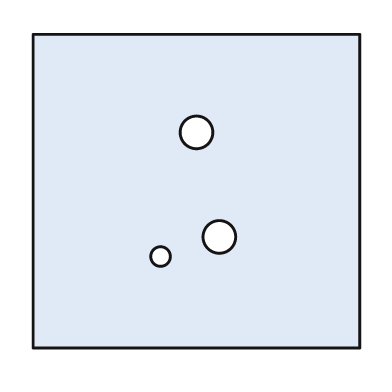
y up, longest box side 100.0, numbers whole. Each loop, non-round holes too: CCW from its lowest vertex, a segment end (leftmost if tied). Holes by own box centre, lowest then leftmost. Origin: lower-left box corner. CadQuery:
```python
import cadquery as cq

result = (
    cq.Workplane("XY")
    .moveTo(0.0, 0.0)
    .lineTo(100.0, 0.0)
    .lineTo(100.0, 96.0)
    .lineTo(0.0, 96.0)
    .close()
    .moveTo(39.0, 28.0)
    .circle(3.0)
    .moveTo(57.0, 34.0)
    .circle(5.0)
    .moveTo(50.0, 66.0)
    .circle(5.0)
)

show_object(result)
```